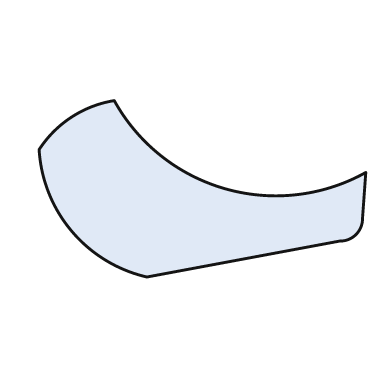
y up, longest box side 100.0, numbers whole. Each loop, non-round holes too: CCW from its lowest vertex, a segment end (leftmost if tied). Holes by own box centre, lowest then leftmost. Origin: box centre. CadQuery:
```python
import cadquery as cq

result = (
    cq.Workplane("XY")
    .moveTo(-17.0, -27.0)
    .lineTo(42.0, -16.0)
    .threePointArc((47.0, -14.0), (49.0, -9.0))
    .lineTo(50.0, 5.0)
    .threePointArc((7.0, 0.0), (-27.0, 27.0))
    .threePointArc((-40.0, 22.0), (-50.0, 12.0))
    .threePointArc((-40.0, -13.0), (-17.0, -27.0))
    .close()
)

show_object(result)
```